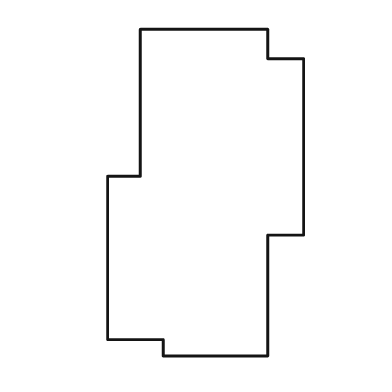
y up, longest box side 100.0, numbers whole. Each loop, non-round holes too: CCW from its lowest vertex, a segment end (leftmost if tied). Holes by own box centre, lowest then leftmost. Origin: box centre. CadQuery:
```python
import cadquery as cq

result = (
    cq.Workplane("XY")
    .moveTo(-13.0, -50.0)
    .lineTo(19.0, -50.0)
    .lineTo(19.0, -13.0)
    .lineTo(30.0, -13.0)
    .lineTo(30.0, 41.0)
    .lineTo(19.0, 41.0)
    .lineTo(19.0, 50.0)
    .lineTo(-20.0, 50.0)
    .lineTo(-20.0, 5.0)
    .lineTo(-30.0, 5.0)
    .lineTo(-30.0, -45.0)
    .lineTo(-13.0, -45.0)
    .close()
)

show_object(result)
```